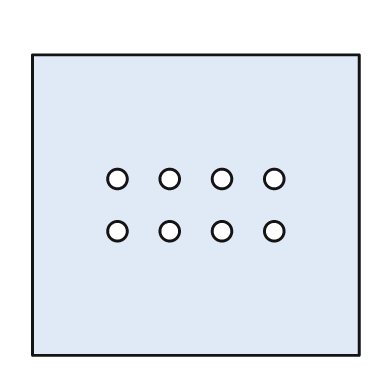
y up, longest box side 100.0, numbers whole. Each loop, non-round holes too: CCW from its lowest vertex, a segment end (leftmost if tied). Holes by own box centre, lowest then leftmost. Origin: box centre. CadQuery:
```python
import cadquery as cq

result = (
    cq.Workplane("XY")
    .moveTo(-50.0, -46.0)
    .lineTo(50.0, -46.0)
    .lineTo(50.0, 46.0)
    .lineTo(-50.0, 46.0)
    .close()
    .moveTo(-24.0, -8.0)
    .circle(3.0)
    .moveTo(-8.0, -8.0)
    .circle(3.0)
    .moveTo(8.0, -8.0)
    .circle(3.0)
    .moveTo(24.0, -8.0)
    .circle(3.0)
    .moveTo(-24.0, 8.0)
    .circle(3.0)
    .moveTo(-8.0, 8.0)
    .circle(3.0)
    .moveTo(8.0, 8.0)
    .circle(3.0)
    .moveTo(24.0, 8.0)
    .circle(3.0)
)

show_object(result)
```